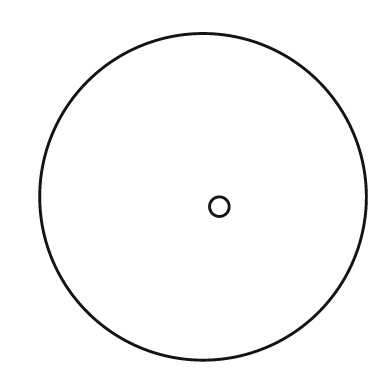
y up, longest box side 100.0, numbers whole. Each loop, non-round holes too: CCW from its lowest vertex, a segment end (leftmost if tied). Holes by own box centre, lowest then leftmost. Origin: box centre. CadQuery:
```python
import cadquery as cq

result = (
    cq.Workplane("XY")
    .moveTo(0.0, 0.0)
    .circle(50.0)
    .moveTo(5.0, -3.0)
    .circle(3.0)
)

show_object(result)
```